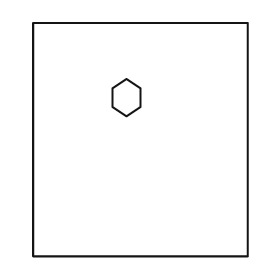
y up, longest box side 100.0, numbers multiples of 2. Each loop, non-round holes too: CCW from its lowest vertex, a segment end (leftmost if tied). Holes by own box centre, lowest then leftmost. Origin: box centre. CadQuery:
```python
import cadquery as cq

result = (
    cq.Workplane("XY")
    .moveTo(-46.0, -50.0)
    .lineTo(46.0, -50.0)
    .lineTo(46.0, 50.0)
    .lineTo(-46.0, 50.0)
    .close()
    .moveTo(-6.0, 10.0)
    .lineTo(0.0, 14.0)
    .lineTo(0.0, 22.0)
    .lineTo(-6.0, 26.0)
    .lineTo(-12.0, 22.0)
    .lineTo(-12.0, 14.0)
    .close()
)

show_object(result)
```